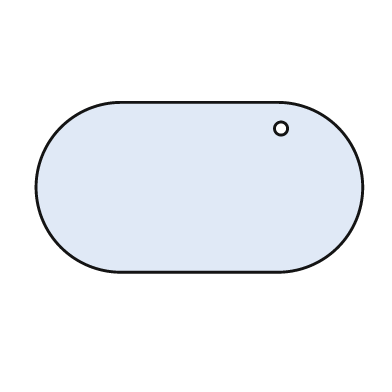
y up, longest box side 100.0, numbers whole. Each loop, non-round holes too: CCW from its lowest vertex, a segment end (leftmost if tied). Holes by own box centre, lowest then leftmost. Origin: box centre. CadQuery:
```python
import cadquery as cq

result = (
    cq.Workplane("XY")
    .moveTo(-24.0, -26.0)
    .lineTo(24.0, -26.0)
    .threePointArc((50.0, 0.0), (24.0, 26.0))
    .lineTo(-24.0, 26.0)
    .threePointArc((-50.0, 0.0), (-24.0, -26.0))
    .close()
    .moveTo(25.0, 18.0)
    .circle(2.0)
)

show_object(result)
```